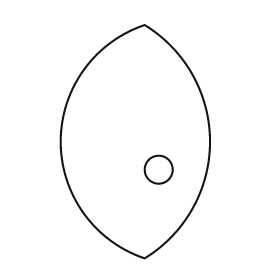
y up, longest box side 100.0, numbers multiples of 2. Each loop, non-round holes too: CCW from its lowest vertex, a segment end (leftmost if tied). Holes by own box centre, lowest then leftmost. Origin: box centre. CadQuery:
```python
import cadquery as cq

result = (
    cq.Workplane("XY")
    .moveTo(4.0, -50.0)
    .threePointArc((32.0, 0.0), (4.0, 50.0))
    .threePointArc((-32.0, 0.0), (4.0, -50.0))
    .close()
    .moveTo(10.0, -12.0)
    .circle(6.0)
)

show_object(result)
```